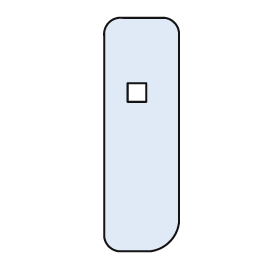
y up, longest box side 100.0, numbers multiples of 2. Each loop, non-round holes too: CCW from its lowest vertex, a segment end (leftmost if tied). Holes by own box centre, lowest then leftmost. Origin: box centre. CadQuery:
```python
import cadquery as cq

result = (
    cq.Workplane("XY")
    .moveTo(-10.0, -50.0)
    .lineTo(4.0, -50.0)
    .threePointArc((12.0, -46.0), (16.0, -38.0))
    .lineTo(16.0, 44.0)
    .threePointArc((14.0, 48.0), (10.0, 50.0))
    .lineTo(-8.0, 50.0)
    .threePointArc((-14.0, 48.0), (-16.0, 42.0))
    .lineTo(-16.0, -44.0)
    .threePointArc((-14.0, -48.0), (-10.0, -50.0))
    .close()
    .moveTo(-6.0, 14.0)
    .lineTo(2.0, 14.0)
    .lineTo(2.0, 22.0)
    .lineTo(-6.0, 22.0)
    .close()
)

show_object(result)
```